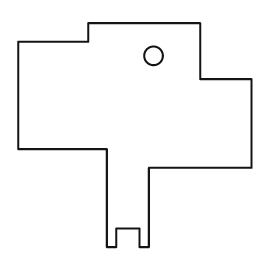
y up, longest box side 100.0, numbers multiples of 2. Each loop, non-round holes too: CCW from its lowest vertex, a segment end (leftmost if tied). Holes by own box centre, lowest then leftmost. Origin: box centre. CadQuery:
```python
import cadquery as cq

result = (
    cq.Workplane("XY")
    .moveTo(-12.0, -48.0)
    .lineTo(-8.0, -48.0)
    .lineTo(-8.0, -40.0)
    .lineTo(2.0, -40.0)
    .lineTo(2.0, -48.0)
    .lineTo(6.0, -48.0)
    .lineTo(6.0, -14.0)
    .lineTo(50.0, -14.0)
    .lineTo(50.0, 24.0)
    .lineTo(28.0, 24.0)
    .lineTo(28.0, 48.0)
    .lineTo(-20.0, 48.0)
    .lineTo(-20.0, 40.0)
    .lineTo(-50.0, 40.0)
    .lineTo(-50.0, -6.0)
    .lineTo(-12.0, -6.0)
    .close()
    .moveTo(8.0, 34.0)
    .circle(4.0)
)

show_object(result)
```